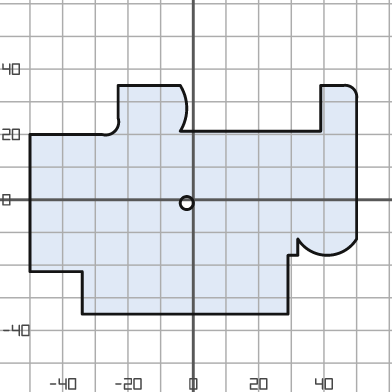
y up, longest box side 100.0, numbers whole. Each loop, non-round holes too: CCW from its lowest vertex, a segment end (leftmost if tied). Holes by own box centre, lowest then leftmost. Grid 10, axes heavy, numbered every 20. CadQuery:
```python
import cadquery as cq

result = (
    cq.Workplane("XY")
    .moveTo(-34.0, -35.0)
    .lineTo(29.0, -35.0)
    .lineTo(29.0, -17.0)
    .lineTo(32.0, -17.0)
    .lineTo(32.0, -12.0)
    .threePointArc((41.0, -17.0), (50.0, -12.0))
    .lineTo(50.0, 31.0)
    .threePointArc((49.0, 34.0), (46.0, 35.0))
    .lineTo(39.0, 35.0)
    .lineTo(39.0, 21.0)
    .lineTo(-4.0, 21.0)
    .threePointArc((-2.0, 28.0), (-4.0, 35.0))
    .lineTo(-23.0, 35.0)
    .lineTo(-23.0, 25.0)
    .threePointArc((-24.0, 21.0), (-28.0, 20.0))
    .lineTo(-50.0, 20.0)
    .lineTo(-50.0, -22.0)
    .lineTo(-34.0, -22.0)
    .close()
    .moveTo(-2.0, -1.0)
    .circle(2.0)
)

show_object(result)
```